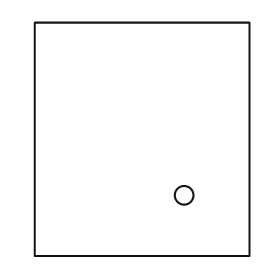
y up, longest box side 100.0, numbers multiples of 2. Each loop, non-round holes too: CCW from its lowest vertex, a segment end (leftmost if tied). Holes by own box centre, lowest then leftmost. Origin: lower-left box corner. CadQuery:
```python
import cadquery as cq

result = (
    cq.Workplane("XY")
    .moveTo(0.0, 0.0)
    .lineTo(92.0, 0.0)
    .lineTo(92.0, 100.0)
    .lineTo(0.0, 100.0)
    .close()
    .moveTo(64.0, 26.0)
    .circle(4.0)
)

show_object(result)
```